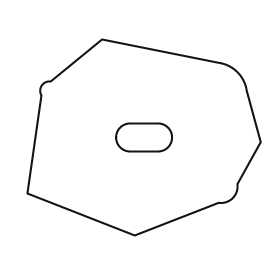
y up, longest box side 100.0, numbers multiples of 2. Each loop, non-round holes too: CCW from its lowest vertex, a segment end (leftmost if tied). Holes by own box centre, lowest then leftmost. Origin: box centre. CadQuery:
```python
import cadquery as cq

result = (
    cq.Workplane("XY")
    .moveTo(-4.0, -42.0)
    .lineTo(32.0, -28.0)
    .threePointArc((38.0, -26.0), (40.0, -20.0))
    .lineTo(50.0, -2.0)
    .lineTo(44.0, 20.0)
    .threePointArc((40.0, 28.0), (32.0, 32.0))
    .lineTo(-18.0, 42.0)
    .lineTo(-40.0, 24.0)
    .threePointArc((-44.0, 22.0), (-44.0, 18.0))
    .lineTo(-50.0, -24.0)
    .close()
    .moveTo(-6.0, -6.0)
    .lineTo(6.0, -6.0)
    .threePointArc((12.0, 0.0), (6.0, 6.0))
    .lineTo(-6.0, 6.0)
    .threePointArc((-12.0, 0.0), (-6.0, -6.0))
    .close()
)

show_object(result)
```